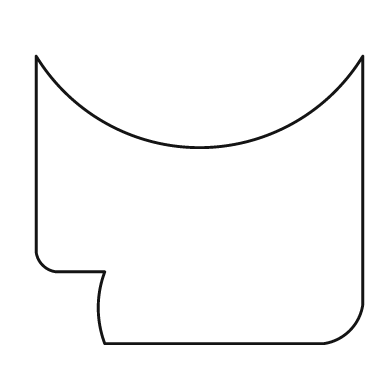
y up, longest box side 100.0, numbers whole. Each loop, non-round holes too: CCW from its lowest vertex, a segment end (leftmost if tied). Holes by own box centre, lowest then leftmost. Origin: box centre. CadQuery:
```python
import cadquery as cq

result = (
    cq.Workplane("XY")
    .moveTo(-29.0, -44.0)
    .lineTo(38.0, -44.0)
    .threePointArc((46.0, -40.0), (50.0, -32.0))
    .lineTo(50.0, 44.0)
    .threePointArc((0.0, 16.0), (-50.0, 44.0))
    .lineTo(-50.0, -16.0)
    .threePointArc((-48.0, -20.0), (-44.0, -22.0))
    .lineTo(-29.0, -22.0)
    .threePointArc((-31.0, -33.0), (-29.0, -44.0))
    .close()
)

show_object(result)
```